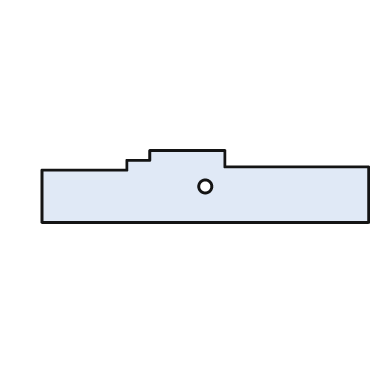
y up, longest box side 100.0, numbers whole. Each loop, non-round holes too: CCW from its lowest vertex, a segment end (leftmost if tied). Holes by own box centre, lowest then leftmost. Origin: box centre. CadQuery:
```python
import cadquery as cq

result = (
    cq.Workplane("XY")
    .moveTo(-50.0, -11.0)
    .lineTo(50.0, -11.0)
    .lineTo(50.0, 6.0)
    .lineTo(6.0, 6.0)
    .lineTo(6.0, 11.0)
    .lineTo(-17.0, 11.0)
    .lineTo(-17.0, 8.0)
    .lineTo(-24.0, 8.0)
    .lineTo(-24.0, 5.0)
    .lineTo(-50.0, 5.0)
    .close()
    .moveTo(0.0, 0.0)
    .circle(2.0)
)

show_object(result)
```